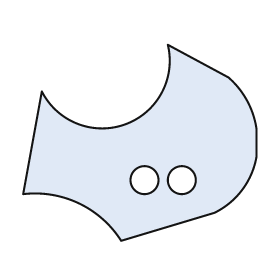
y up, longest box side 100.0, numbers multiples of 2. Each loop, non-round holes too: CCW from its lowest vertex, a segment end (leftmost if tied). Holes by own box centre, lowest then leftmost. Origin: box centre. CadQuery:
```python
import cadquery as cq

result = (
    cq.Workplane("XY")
    .moveTo(-8.0, -42.0)
    .lineTo(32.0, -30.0)
    .threePointArc((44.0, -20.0), (50.0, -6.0))
    .lineTo(50.0, 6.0)
    .threePointArc((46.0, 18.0), (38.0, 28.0))
    .lineTo(12.0, 42.0)
    .threePointArc((-6.0, 8.0), (-42.0, 22.0))
    .lineTo(-50.0, -22.0)
    .threePointArc((-26.0, -26.0), (-8.0, -42.0))
    .close()
    .moveTo(2.0, -16.0)
    .circle(6.0)
    .moveTo(18.0, -16.0)
    .circle(6.0)
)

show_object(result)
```